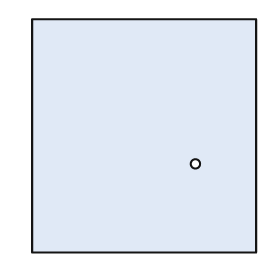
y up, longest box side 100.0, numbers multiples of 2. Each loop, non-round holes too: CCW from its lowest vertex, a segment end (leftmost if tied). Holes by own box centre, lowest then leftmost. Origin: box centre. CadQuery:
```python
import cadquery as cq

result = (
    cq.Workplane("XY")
    .moveTo(-48.0, -50.0)
    .lineTo(48.0, -50.0)
    .lineTo(48.0, 50.0)
    .lineTo(-48.0, 50.0)
    .close()
    .moveTo(22.0, -12.0)
    .circle(2.0)
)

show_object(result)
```